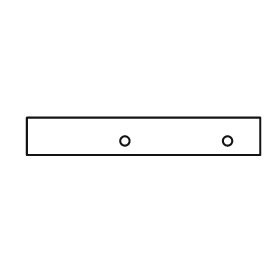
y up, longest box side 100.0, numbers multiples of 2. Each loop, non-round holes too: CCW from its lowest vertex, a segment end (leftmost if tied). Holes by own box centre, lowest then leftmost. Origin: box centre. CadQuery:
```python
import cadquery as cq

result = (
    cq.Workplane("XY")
    .moveTo(-50.0, -8.0)
    .lineTo(50.0, -8.0)
    .lineTo(50.0, 8.0)
    .lineTo(-50.0, 8.0)
    .close()
    .moveTo(-8.0, -2.0)
    .circle(2.0)
    .moveTo(36.0, -2.0)
    .circle(2.0)
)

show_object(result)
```